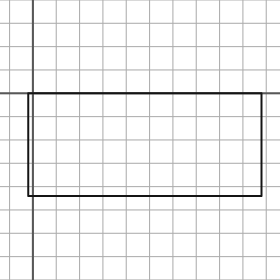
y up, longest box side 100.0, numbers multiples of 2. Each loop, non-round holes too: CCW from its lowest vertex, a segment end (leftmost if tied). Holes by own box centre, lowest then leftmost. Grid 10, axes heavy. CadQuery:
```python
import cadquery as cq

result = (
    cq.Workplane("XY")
    .moveTo(-2.0, -44.0)
    .lineTo(98.0, -44.0)
    .lineTo(98.0, 0.0)
    .lineTo(-2.0, 0.0)
    .close()
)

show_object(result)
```